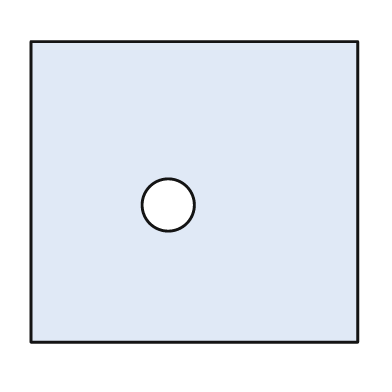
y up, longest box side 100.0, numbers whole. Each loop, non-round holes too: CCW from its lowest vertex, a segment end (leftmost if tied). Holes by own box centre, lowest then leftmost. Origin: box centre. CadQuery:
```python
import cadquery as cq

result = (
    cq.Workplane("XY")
    .moveTo(-50.0, -46.0)
    .lineTo(50.0, -46.0)
    .lineTo(50.0, 46.0)
    .lineTo(-50.0, 46.0)
    .close()
    .moveTo(-8.0, -4.0)
    .circle(8.0)
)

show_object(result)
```